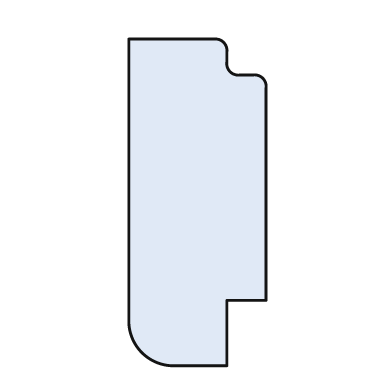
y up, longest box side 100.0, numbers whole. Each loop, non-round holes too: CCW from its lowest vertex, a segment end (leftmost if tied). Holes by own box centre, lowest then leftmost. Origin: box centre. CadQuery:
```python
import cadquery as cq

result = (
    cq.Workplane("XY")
    .moveTo(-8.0, -50.0)
    .lineTo(9.0, -50.0)
    .lineTo(9.0, -30.0)
    .lineTo(21.0, -30.0)
    .lineTo(21.0, 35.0)
    .threePointArc((20.0, 38.0), (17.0, 39.0))
    .lineTo(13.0, 39.0)
    .threePointArc((10.0, 40.0), (9.0, 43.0))
    .lineTo(9.0, 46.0)
    .threePointArc((8.0, 49.0), (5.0, 50.0))
    .lineTo(-21.0, 50.0)
    .lineTo(-21.0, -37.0)
    .threePointArc((-17.0, -46.0), (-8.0, -50.0))
    .close()
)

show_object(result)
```